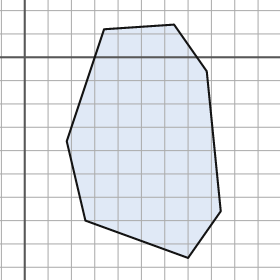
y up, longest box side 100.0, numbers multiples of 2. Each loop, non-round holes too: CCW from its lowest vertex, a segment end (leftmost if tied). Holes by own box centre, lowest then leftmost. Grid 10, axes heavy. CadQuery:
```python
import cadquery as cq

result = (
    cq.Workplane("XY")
    .moveTo(70.0, -86.0)
    .lineTo(84.0, -66.0)
    .lineTo(78.0, -6.0)
    .lineTo(64.0, 14.0)
    .lineTo(34.0, 12.0)
    .lineTo(18.0, -36.0)
    .lineTo(26.0, -70.0)
    .close()
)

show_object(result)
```